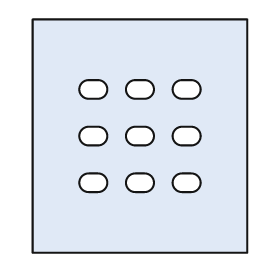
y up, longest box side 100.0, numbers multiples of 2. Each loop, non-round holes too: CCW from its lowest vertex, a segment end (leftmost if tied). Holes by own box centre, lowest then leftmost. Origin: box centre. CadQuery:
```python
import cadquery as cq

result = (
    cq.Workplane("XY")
    .moveTo(-46.0, -50.0)
    .lineTo(46.0, -50.0)
    .lineTo(46.0, 50.0)
    .lineTo(-46.0, 50.0)
    .close()
    .moveTo(-22.0, -24.0)
    .lineTo(-18.0, -24.0)
    .threePointArc((-14.0, -20.0), (-18.0, -16.0))
    .lineTo(-22.0, -16.0)
    .threePointArc((-26.0, -20.0), (-22.0, -24.0))
    .close()
    .moveTo(-2.0, -24.0)
    .lineTo(2.0, -24.0)
    .threePointArc((6.0, -20.0), (2.0, -16.0))
    .lineTo(-2.0, -16.0)
    .threePointArc((-6.0, -20.0), (-2.0, -24.0))
    .close()
    .moveTo(18.0, -24.0)
    .lineTo(22.0, -24.0)
    .threePointArc((26.0, -20.0), (22.0, -16.0))
    .lineTo(18.0, -16.0)
    .threePointArc((14.0, -20.0), (18.0, -24.0))
    .close()
    .moveTo(-22.0, -4.0)
    .lineTo(-18.0, -4.0)
    .threePointArc((-14.0, 0.0), (-18.0, 4.0))
    .lineTo(-22.0, 4.0)
    .threePointArc((-26.0, 0.0), (-22.0, -4.0))
    .close()
    .moveTo(-2.0, -4.0)
    .lineTo(2.0, -4.0)
    .threePointArc((6.0, 0.0), (2.0, 4.0))
    .lineTo(-2.0, 4.0)
    .threePointArc((-6.0, 0.0), (-2.0, -4.0))
    .close()
    .moveTo(18.0, -4.0)
    .lineTo(22.0, -4.0)
    .threePointArc((26.0, 0.0), (22.0, 4.0))
    .lineTo(18.0, 4.0)
    .threePointArc((14.0, 0.0), (18.0, -4.0))
    .close()
    .moveTo(-22.0, 16.0)
    .lineTo(-18.0, 16.0)
    .threePointArc((-14.0, 20.0), (-18.0, 24.0))
    .lineTo(-22.0, 24.0)
    .threePointArc((-26.0, 20.0), (-22.0, 16.0))
    .close()
    .moveTo(-2.0, 16.0)
    .lineTo(2.0, 16.0)
    .threePointArc((6.0, 20.0), (2.0, 24.0))
    .lineTo(-2.0, 24.0)
    .threePointArc((-6.0, 20.0), (-2.0, 16.0))
    .close()
    .moveTo(18.0, 16.0)
    .lineTo(22.0, 16.0)
    .threePointArc((26.0, 20.0), (22.0, 24.0))
    .lineTo(18.0, 24.0)
    .threePointArc((14.0, 20.0), (18.0, 16.0))
    .close()
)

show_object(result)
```